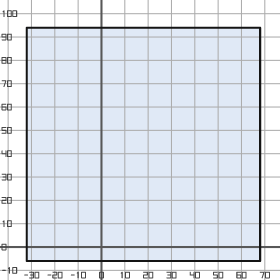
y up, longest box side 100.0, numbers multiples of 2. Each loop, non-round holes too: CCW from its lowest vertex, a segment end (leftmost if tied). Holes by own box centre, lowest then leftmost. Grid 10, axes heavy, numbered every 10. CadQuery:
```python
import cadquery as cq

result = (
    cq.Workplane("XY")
    .moveTo(-32.0, -6.0)
    .lineTo(68.0, -6.0)
    .lineTo(68.0, 94.0)
    .lineTo(-32.0, 94.0)
    .close()
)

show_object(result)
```